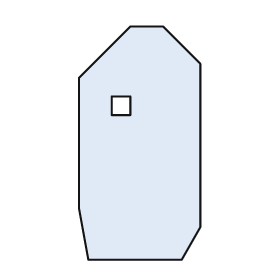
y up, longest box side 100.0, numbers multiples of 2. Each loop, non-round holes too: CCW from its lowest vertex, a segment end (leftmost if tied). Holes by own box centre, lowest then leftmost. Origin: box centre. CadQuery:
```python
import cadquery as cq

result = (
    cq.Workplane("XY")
    .moveTo(-22.0, -50.0)
    .lineTo(18.0, -50.0)
    .lineTo(26.0, -36.0)
    .lineTo(26.0, 34.0)
    .lineTo(10.0, 50.0)
    .lineTo(-4.0, 50.0)
    .lineTo(-26.0, 28.0)
    .lineTo(-26.0, -28.0)
    .close()
    .moveTo(-12.0, 12.0)
    .lineTo(-4.0, 12.0)
    .lineTo(-4.0, 20.0)
    .lineTo(-12.0, 20.0)
    .close()
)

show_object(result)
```